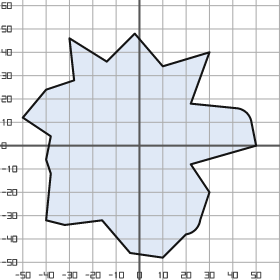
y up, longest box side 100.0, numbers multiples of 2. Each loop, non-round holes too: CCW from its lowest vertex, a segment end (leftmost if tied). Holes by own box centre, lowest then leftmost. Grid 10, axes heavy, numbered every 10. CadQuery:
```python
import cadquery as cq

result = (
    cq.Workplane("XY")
    .moveTo(10.0, -48.0)
    .lineTo(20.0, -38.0)
    .threePointArc((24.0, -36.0), (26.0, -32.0))
    .lineTo(30.0, -20.0)
    .lineTo(22.0, -8.0)
    .lineTo(50.0, 0.0)
    .lineTo(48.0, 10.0)
    .threePointArc((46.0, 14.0), (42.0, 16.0))
    .lineTo(22.0, 18.0)
    .lineTo(30.0, 40.0)
    .lineTo(10.0, 34.0)
    .lineTo(-2.0, 48.0)
    .lineTo(-14.0, 36.0)
    .lineTo(-30.0, 46.0)
    .lineTo(-28.0, 28.0)
    .lineTo(-40.0, 24.0)
    .lineTo(-50.0, 12.0)
    .lineTo(-38.0, 4.0)
    .lineTo(-40.0, -6.0)
    .lineTo(-38.0, -12.0)
    .lineTo(-40.0, -32.0)
    .lineTo(-32.0, -34.0)
    .lineTo(-16.0, -32.0)
    .lineTo(-4.0, -46.0)
    .close()
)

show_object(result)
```